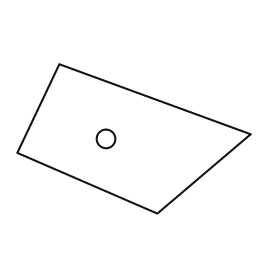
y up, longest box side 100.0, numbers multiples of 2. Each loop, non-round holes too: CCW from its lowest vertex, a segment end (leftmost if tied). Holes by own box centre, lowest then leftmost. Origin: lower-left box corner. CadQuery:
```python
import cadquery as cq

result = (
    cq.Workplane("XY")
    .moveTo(60.0, 0.0)
    .lineTo(100.0, 34.0)
    .lineTo(18.0, 64.0)
    .lineTo(0.0, 26.0)
    .close()
    .moveTo(38.0, 32.0)
    .circle(4.0)
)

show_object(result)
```